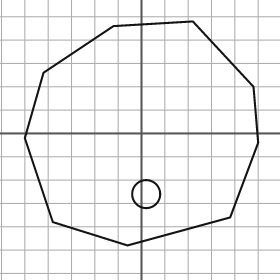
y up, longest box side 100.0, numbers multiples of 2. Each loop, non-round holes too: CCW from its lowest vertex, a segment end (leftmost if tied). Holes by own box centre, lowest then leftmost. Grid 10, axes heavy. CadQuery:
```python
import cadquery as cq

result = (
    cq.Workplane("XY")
    .moveTo(-6.0, -48.0)
    .lineTo(38.0, -36.0)
    .lineTo(50.0, -4.0)
    .lineTo(48.0, 20.0)
    .lineTo(22.0, 48.0)
    .lineTo(-12.0, 46.0)
    .lineTo(-42.0, 26.0)
    .lineTo(-50.0, -2.0)
    .lineTo(-38.0, -38.0)
    .close()
    .moveTo(2.0, -26.0)
    .circle(6.0)
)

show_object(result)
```